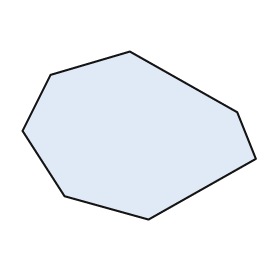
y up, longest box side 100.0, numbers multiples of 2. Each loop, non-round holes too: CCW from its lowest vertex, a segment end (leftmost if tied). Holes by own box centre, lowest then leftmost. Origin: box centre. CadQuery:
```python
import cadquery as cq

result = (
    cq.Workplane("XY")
    .moveTo(4.0, -36.0)
    .lineTo(50.0, -10.0)
    .lineTo(42.0, 10.0)
    .lineTo(-4.0, 36.0)
    .lineTo(-38.0, 26.0)
    .lineTo(-50.0, 2.0)
    .lineTo(-32.0, -26.0)
    .close()
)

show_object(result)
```